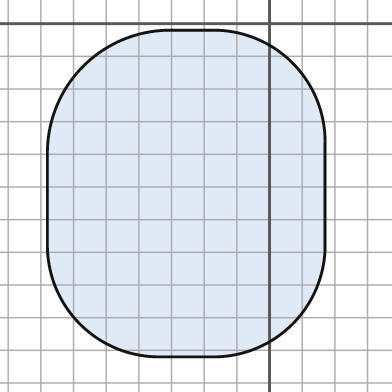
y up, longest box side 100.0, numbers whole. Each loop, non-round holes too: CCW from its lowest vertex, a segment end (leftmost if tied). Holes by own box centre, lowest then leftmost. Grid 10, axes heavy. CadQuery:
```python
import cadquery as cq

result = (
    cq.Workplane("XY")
    .moveTo(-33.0, -102.0)
    .lineTo(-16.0, -102.0)
    .threePointArc((7.0, -92.0), (17.0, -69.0))
    .lineTo(17.0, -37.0)
    .threePointArc((7.0, -12.0), (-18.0, -2.0))
    .lineTo(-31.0, -2.0)
    .threePointArc((-57.0, -13.0), (-68.0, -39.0))
    .lineTo(-68.0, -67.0)
    .threePointArc((-58.0, -92.0), (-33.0, -102.0))
    .close()
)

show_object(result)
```